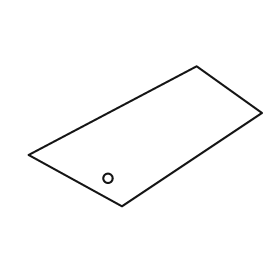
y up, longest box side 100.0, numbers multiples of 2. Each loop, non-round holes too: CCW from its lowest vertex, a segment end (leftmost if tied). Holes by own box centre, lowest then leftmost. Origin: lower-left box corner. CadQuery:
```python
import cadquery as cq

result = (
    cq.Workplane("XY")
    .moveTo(40.0, 0.0)
    .lineTo(100.0, 40.0)
    .lineTo(72.0, 60.0)
    .lineTo(0.0, 22.0)
    .close()
    .moveTo(34.0, 12.0)
    .circle(2.0)
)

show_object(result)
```